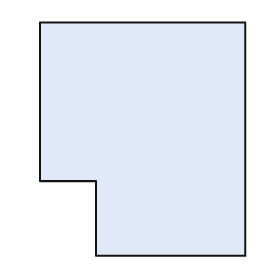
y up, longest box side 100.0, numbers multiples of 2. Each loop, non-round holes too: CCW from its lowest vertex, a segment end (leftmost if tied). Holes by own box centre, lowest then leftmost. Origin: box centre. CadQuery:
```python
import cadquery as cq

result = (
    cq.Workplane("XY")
    .moveTo(-20.0, -50.0)
    .lineTo(44.0, -50.0)
    .lineTo(44.0, 50.0)
    .lineTo(-44.0, 50.0)
    .lineTo(-44.0, -18.0)
    .lineTo(-20.0, -18.0)
    .close()
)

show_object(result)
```